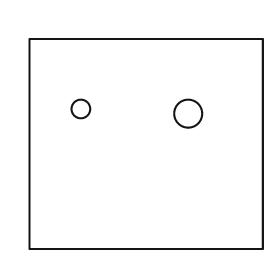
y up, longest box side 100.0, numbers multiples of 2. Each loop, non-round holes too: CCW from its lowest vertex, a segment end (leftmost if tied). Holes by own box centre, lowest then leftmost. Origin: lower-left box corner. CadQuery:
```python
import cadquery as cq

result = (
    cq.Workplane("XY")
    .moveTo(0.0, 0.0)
    .lineTo(100.0, 0.0)
    .lineTo(100.0, 90.0)
    .lineTo(0.0, 90.0)
    .close()
    .moveTo(68.0, 58.0)
    .circle(6.0)
    .moveTo(22.0, 60.0)
    .circle(4.0)
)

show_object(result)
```